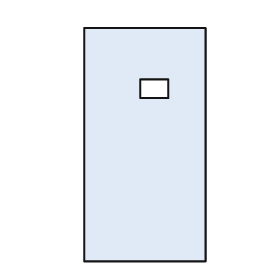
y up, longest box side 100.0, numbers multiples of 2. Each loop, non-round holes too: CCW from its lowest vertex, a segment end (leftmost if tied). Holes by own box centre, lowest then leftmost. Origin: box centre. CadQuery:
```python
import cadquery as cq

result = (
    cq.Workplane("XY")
    .moveTo(-26.0, -50.0)
    .lineTo(26.0, -50.0)
    .lineTo(26.0, 50.0)
    .lineTo(-26.0, 50.0)
    .close()
    .moveTo(-2.0, 20.0)
    .lineTo(10.0, 20.0)
    .lineTo(10.0, 28.0)
    .lineTo(-2.0, 28.0)
    .close()
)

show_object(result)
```